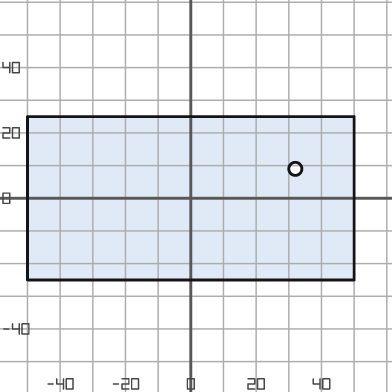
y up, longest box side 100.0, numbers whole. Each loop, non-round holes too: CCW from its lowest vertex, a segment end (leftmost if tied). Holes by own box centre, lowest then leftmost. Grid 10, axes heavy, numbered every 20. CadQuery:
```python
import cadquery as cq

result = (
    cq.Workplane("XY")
    .moveTo(-50.0, -25.0)
    .lineTo(50.0, -25.0)
    .lineTo(50.0, 25.0)
    .lineTo(-50.0, 25.0)
    .close()
    .moveTo(32.0, 9.0)
    .circle(2.0)
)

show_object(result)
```